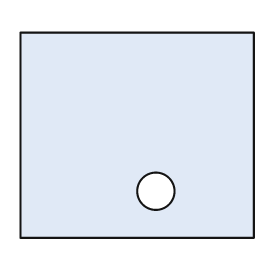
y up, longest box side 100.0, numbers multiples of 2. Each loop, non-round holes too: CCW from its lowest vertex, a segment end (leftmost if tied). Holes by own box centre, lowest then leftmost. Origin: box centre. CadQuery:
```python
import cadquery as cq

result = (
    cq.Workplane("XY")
    .moveTo(-50.0, -44.0)
    .lineTo(50.0, -44.0)
    .lineTo(50.0, 44.0)
    .lineTo(-50.0, 44.0)
    .close()
    .moveTo(8.0, -24.0)
    .circle(8.0)
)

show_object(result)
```